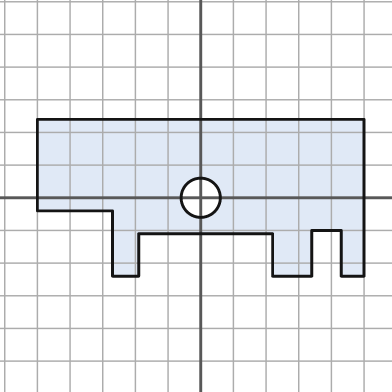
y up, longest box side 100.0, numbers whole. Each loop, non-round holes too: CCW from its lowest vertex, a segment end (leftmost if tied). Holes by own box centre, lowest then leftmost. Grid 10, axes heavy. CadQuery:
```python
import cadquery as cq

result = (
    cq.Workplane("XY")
    .moveTo(-27.0, -24.0)
    .lineTo(-19.0, -24.0)
    .lineTo(-19.0, -11.0)
    .lineTo(22.0, -11.0)
    .lineTo(22.0, -24.0)
    .lineTo(34.0, -24.0)
    .lineTo(34.0, -10.0)
    .lineTo(43.0, -10.0)
    .lineTo(43.0, -24.0)
    .lineTo(50.0, -24.0)
    .lineTo(50.0, 24.0)
    .lineTo(-50.0, 24.0)
    .lineTo(-50.0, -4.0)
    .lineTo(-27.0, -4.0)
    .close()
    .moveTo(0.0, 0.0)
    .circle(6.0)
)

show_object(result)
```